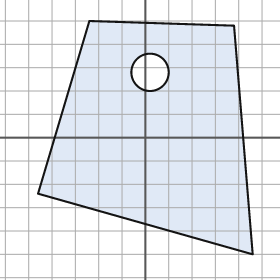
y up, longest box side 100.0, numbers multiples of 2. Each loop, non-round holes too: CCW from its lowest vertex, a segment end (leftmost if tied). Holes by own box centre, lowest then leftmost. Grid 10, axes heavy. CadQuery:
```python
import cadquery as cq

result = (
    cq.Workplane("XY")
    .moveTo(46.0, -50.0)
    .lineTo(38.0, 48.0)
    .lineTo(-24.0, 50.0)
    .lineTo(-46.0, -24.0)
    .close()
    .moveTo(2.0, 28.0)
    .circle(8.0)
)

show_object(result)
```